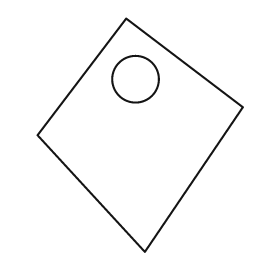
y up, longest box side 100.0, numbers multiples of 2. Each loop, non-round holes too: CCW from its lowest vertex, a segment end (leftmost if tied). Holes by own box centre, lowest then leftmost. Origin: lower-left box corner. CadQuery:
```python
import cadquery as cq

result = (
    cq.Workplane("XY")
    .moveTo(46.0, 0.0)
    .lineTo(88.0, 62.0)
    .lineTo(38.0, 100.0)
    .lineTo(0.0, 50.0)
    .close()
    .moveTo(42.0, 74.0)
    .circle(10.0)
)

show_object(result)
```